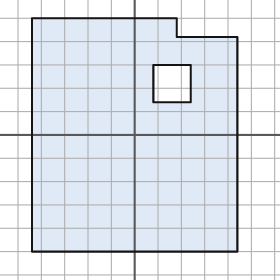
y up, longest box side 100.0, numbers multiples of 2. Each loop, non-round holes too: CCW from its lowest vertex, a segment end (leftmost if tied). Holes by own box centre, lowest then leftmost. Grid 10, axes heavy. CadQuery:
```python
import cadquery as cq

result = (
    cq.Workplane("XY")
    .moveTo(-44.0, -50.0)
    .lineTo(44.0, -50.0)
    .lineTo(44.0, 42.0)
    .lineTo(18.0, 42.0)
    .lineTo(18.0, 50.0)
    .lineTo(-44.0, 50.0)
    .close()
    .moveTo(8.0, 14.0)
    .lineTo(24.0, 14.0)
    .lineTo(24.0, 30.0)
    .lineTo(8.0, 30.0)
    .close()
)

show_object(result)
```